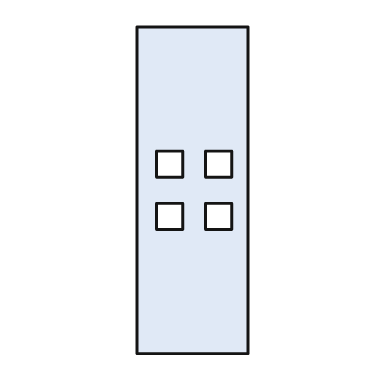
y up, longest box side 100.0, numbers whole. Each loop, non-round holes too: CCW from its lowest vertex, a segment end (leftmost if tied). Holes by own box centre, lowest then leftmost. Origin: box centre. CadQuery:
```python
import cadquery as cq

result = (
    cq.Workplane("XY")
    .moveTo(-17.0, -50.0)
    .lineTo(17.0, -50.0)
    .lineTo(17.0, 50.0)
    .lineTo(-17.0, 50.0)
    .close()
    .moveTo(-11.0, -12.0)
    .lineTo(-3.0, -12.0)
    .lineTo(-3.0, -4.0)
    .lineTo(-11.0, -4.0)
    .close()
    .moveTo(4.0, -12.0)
    .lineTo(12.0, -12.0)
    .lineTo(12.0, -4.0)
    .lineTo(4.0, -4.0)
    .close()
    .moveTo(-11.0, 4.0)
    .lineTo(-3.0, 4.0)
    .lineTo(-3.0, 12.0)
    .lineTo(-11.0, 12.0)
    .close()
    .moveTo(4.0, 4.0)
    .lineTo(12.0, 4.0)
    .lineTo(12.0, 12.0)
    .lineTo(4.0, 12.0)
    .close()
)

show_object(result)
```